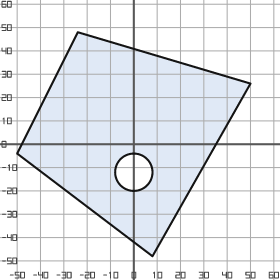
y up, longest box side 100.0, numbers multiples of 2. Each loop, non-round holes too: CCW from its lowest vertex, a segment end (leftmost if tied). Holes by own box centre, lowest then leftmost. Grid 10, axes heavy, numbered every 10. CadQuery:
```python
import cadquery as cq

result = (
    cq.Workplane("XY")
    .moveTo(8.0, -48.0)
    .lineTo(50.0, 26.0)
    .lineTo(-24.0, 48.0)
    .lineTo(-50.0, -4.0)
    .close()
    .moveTo(0.0, -12.0)
    .circle(8.0)
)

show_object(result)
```